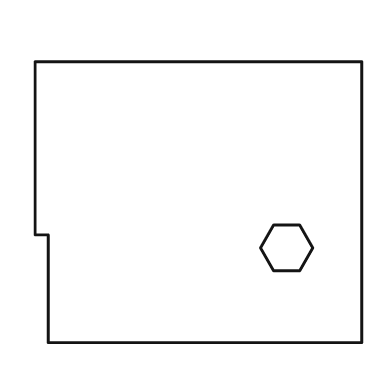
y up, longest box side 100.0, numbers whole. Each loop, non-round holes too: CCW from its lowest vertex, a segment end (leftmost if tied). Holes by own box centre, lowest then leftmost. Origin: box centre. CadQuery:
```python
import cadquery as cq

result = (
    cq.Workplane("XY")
    .moveTo(-46.0, -43.0)
    .lineTo(50.0, -43.0)
    .lineTo(50.0, 43.0)
    .lineTo(-50.0, 43.0)
    .lineTo(-50.0, -10.0)
    .lineTo(-46.0, -10.0)
    .close()
    .moveTo(23.0, -21.0)
    .lineTo(31.0, -21.0)
    .lineTo(35.0, -14.0)
    .lineTo(31.0, -7.0)
    .lineTo(23.0, -7.0)
    .lineTo(19.0, -14.0)
    .close()
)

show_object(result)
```